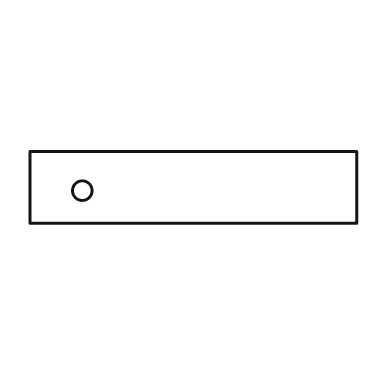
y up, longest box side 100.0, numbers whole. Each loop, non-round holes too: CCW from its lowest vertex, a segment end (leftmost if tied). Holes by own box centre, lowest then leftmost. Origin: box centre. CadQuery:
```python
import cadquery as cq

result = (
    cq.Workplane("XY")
    .moveTo(-50.0, -11.0)
    .lineTo(50.0, -11.0)
    .lineTo(50.0, 11.0)
    .lineTo(-50.0, 11.0)
    .close()
    .moveTo(-34.0, -1.0)
    .circle(3.0)
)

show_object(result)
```